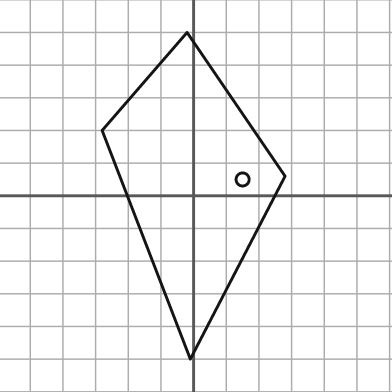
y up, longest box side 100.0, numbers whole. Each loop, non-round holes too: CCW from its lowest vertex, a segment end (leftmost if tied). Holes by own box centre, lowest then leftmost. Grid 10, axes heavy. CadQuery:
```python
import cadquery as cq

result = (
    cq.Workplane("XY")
    .moveTo(-1.0, -50.0)
    .lineTo(28.0, 6.0)
    .lineTo(-2.0, 50.0)
    .lineTo(-28.0, 20.0)
    .close()
    .moveTo(15.0, 5.0)
    .circle(2.0)
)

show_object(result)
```